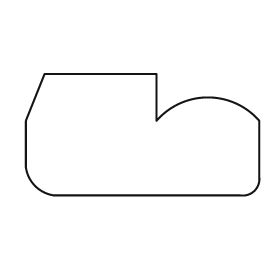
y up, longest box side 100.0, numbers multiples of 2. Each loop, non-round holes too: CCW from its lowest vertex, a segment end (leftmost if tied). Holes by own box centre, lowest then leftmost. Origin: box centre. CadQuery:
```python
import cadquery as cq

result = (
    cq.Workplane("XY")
    .moveTo(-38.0, -26.0)
    .lineTo(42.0, -26.0)
    .threePointArc((48.0, -24.0), (50.0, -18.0))
    .lineTo(50.0, 6.0)
    .threePointArc((28.0, 16.0), (6.0, 6.0))
    .lineTo(6.0, 26.0)
    .lineTo(-42.0, 26.0)
    .lineTo(-50.0, 6.0)
    .lineTo(-50.0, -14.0)
    .threePointArc((-46.0, -22.0), (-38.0, -26.0))
    .close()
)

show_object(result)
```